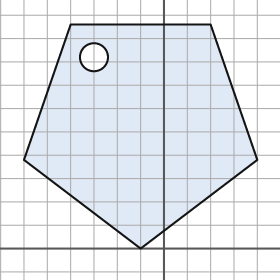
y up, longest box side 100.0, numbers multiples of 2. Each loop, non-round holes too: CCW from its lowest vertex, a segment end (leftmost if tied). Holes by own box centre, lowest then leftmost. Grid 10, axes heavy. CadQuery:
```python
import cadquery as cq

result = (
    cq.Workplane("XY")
    .moveTo(-10.0, 0.0)
    .lineTo(40.0, 38.0)
    .lineTo(20.0, 96.0)
    .lineTo(-40.0, 96.0)
    .lineTo(-60.0, 38.0)
    .close()
    .moveTo(-30.0, 82.0)
    .circle(6.0)
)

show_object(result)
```